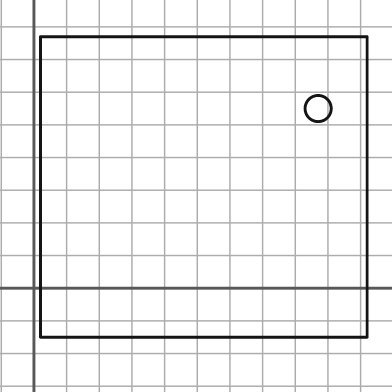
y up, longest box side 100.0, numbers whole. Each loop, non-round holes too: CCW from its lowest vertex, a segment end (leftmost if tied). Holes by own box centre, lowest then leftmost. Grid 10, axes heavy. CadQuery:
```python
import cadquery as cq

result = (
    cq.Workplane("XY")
    .moveTo(2.0, -15.0)
    .lineTo(102.0, -15.0)
    .lineTo(102.0, 77.0)
    .lineTo(2.0, 77.0)
    .close()
    .moveTo(87.0, 55.0)
    .circle(4.0)
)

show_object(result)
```